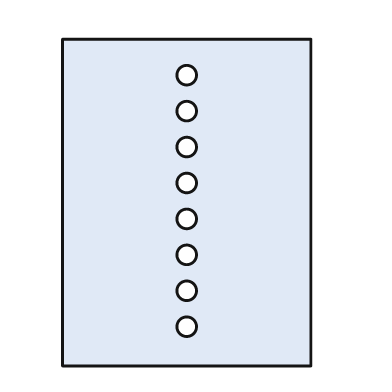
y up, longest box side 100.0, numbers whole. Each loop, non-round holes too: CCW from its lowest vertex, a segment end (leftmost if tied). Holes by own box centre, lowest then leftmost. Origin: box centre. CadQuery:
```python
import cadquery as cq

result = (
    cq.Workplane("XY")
    .moveTo(-38.0, -50.0)
    .lineTo(38.0, -50.0)
    .lineTo(38.0, 50.0)
    .lineTo(-38.0, 50.0)
    .close()
    .moveTo(0.0, -38.0)
    .circle(3.0)
    .moveTo(0.0, -27.0)
    .circle(3.0)
    .moveTo(0.0, -16.0)
    .circle(3.0)
    .moveTo(0.0, -5.0)
    .circle(3.0)
    .moveTo(0.0, 6.0)
    .circle(3.0)
    .moveTo(0.0, 17.0)
    .circle(3.0)
    .moveTo(0.0, 28.0)
    .circle(3.0)
    .moveTo(0.0, 39.0)
    .circle(3.0)
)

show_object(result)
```